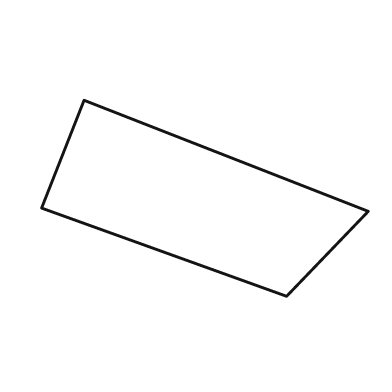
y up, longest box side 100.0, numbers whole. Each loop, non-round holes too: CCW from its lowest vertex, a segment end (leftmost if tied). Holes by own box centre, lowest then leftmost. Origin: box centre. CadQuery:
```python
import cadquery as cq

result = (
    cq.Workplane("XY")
    .moveTo(25.0, -30.0)
    .lineTo(50.0, -4.0)
    .lineTo(-37.0, 30.0)
    .lineTo(-50.0, -3.0)
    .close()
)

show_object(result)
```